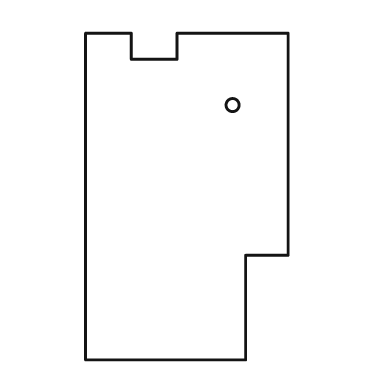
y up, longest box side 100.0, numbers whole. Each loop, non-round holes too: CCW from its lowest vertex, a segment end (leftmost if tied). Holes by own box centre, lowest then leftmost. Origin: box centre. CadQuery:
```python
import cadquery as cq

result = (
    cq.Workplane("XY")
    .moveTo(-31.0, -50.0)
    .lineTo(18.0, -50.0)
    .lineTo(18.0, -18.0)
    .lineTo(31.0, -18.0)
    .lineTo(31.0, 50.0)
    .lineTo(-3.0, 50.0)
    .lineTo(-3.0, 42.0)
    .lineTo(-17.0, 42.0)
    .lineTo(-17.0, 50.0)
    .lineTo(-31.0, 50.0)
    .close()
    .moveTo(14.0, 28.0)
    .circle(2.0)
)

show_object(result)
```